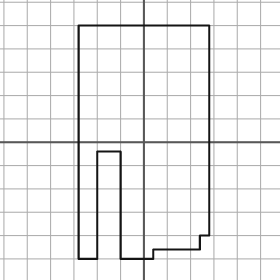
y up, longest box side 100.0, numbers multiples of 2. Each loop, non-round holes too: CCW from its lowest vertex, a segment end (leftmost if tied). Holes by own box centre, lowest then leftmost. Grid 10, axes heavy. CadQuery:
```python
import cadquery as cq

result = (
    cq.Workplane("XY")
    .moveTo(-28.0, -50.0)
    .lineTo(-20.0, -50.0)
    .lineTo(-20.0, -4.0)
    .lineTo(-10.0, -4.0)
    .lineTo(-10.0, -50.0)
    .lineTo(4.0, -50.0)
    .lineTo(4.0, -46.0)
    .lineTo(24.0, -46.0)
    .lineTo(24.0, -40.0)
    .lineTo(28.0, -40.0)
    .lineTo(28.0, 50.0)
    .lineTo(-28.0, 50.0)
    .close()
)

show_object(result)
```